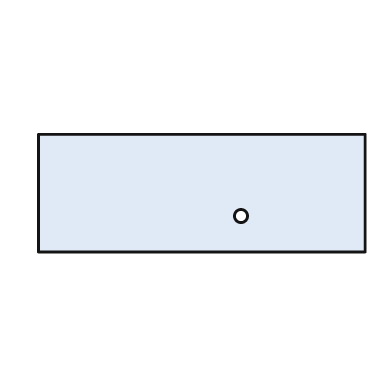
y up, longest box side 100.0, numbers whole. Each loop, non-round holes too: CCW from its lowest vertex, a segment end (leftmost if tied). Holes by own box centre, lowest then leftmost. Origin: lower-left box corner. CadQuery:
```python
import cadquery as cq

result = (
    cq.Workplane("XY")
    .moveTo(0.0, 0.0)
    .lineTo(100.0, 0.0)
    .lineTo(100.0, 36.0)
    .lineTo(0.0, 36.0)
    .close()
    .moveTo(62.0, 11.0)
    .circle(2.0)
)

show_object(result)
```